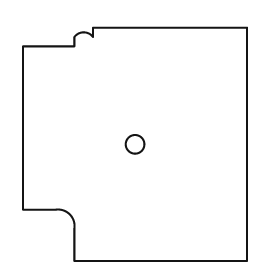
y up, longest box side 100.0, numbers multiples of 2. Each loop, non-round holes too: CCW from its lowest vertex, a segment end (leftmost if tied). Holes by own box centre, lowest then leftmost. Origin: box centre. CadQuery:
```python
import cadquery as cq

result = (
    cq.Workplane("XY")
    .moveTo(-26.0, -50.0)
    .lineTo(48.0, -50.0)
    .lineTo(48.0, 50.0)
    .lineTo(-18.0, 50.0)
    .lineTo(-18.0, 46.0)
    .threePointArc((-22.0, 48.0), (-26.0, 46.0))
    .lineTo(-26.0, 42.0)
    .lineTo(-48.0, 42.0)
    .lineTo(-48.0, -28.0)
    .lineTo(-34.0, -28.0)
    .threePointArc((-28.0, -30.0), (-26.0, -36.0))
    .close()
    .moveTo(0.0, 0.0)
    .circle(4.0)
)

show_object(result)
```